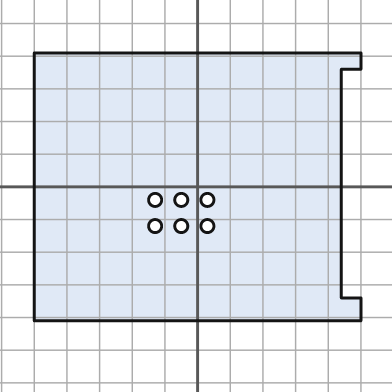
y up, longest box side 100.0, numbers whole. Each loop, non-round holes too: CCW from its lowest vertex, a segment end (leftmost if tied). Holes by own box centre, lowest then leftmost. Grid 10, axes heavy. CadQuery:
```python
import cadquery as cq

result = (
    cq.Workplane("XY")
    .moveTo(-50.0, -41.0)
    .lineTo(50.0, -41.0)
    .lineTo(50.0, -34.0)
    .lineTo(44.0, -34.0)
    .lineTo(44.0, 36.0)
    .lineTo(50.0, 36.0)
    .lineTo(50.0, 41.0)
    .lineTo(-50.0, 41.0)
    .close()
    .moveTo(-13.0, -12.0)
    .circle(2.0)
    .moveTo(-5.0, -12.0)
    .circle(2.0)
    .moveTo(3.0, -12.0)
    .circle(2.0)
    .moveTo(-13.0, -4.0)
    .circle(2.0)
    .moveTo(-5.0, -4.0)
    .circle(2.0)
    .moveTo(3.0, -4.0)
    .circle(2.0)
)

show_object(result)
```